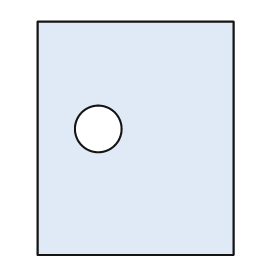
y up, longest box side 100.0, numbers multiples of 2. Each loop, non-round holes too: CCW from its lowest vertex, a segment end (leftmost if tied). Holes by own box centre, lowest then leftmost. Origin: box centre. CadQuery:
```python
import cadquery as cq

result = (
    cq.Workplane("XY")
    .moveTo(-42.0, -50.0)
    .lineTo(42.0, -50.0)
    .lineTo(42.0, 50.0)
    .lineTo(-42.0, 50.0)
    .close()
    .moveTo(-16.0, 4.0)
    .circle(10.0)
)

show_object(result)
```